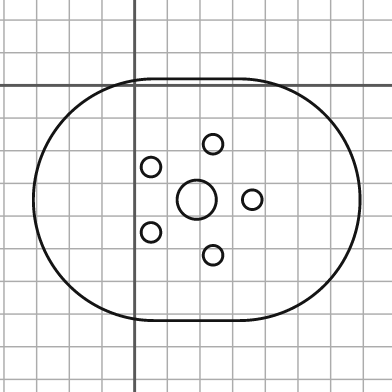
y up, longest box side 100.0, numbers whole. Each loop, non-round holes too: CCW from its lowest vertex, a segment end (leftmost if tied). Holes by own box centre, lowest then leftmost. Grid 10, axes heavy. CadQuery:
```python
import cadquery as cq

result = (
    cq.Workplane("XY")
    .moveTo(6.0, -72.0)
    .lineTo(32.0, -72.0)
    .threePointArc((69.0, -35.0), (32.0, 2.0))
    .lineTo(6.0, 2.0)
    .threePointArc((-31.0, -35.0), (6.0, -72.0))
    .close()
    .moveTo(24.0, -52.0)
    .circle(3.0)
    .moveTo(5.0, -45.0)
    .circle(3.0)
    .moveTo(19.0, -35.0)
    .circle(6.0)
    .moveTo(36.0, -35.0)
    .circle(3.0)
    .moveTo(5.0, -25.0)
    .circle(3.0)
    .moveTo(24.0, -18.0)
    .circle(3.0)
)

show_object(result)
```